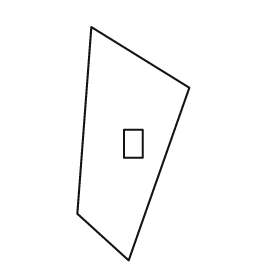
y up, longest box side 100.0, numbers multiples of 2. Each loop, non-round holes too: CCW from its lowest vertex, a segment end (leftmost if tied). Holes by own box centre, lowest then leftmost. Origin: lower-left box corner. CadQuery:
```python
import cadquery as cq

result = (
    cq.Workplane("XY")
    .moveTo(22.0, 0.0)
    .lineTo(48.0, 74.0)
    .lineTo(6.0, 100.0)
    .lineTo(0.0, 20.0)
    .close()
    .moveTo(20.0, 44.0)
    .lineTo(28.0, 44.0)
    .lineTo(28.0, 56.0)
    .lineTo(20.0, 56.0)
    .close()
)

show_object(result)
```